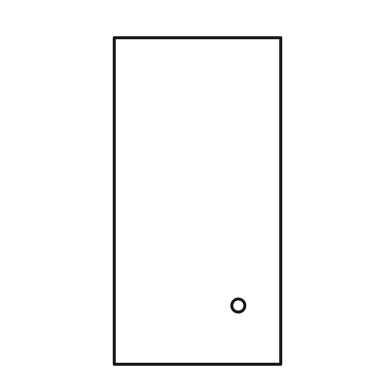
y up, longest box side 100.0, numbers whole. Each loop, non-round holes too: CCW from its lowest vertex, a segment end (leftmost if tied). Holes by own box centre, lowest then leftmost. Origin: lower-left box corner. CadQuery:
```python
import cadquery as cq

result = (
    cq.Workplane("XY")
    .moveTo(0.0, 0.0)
    .lineTo(51.0, 0.0)
    .lineTo(51.0, 100.0)
    .lineTo(0.0, 100.0)
    .close()
    .moveTo(38.0, 18.0)
    .circle(2.0)
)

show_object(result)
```